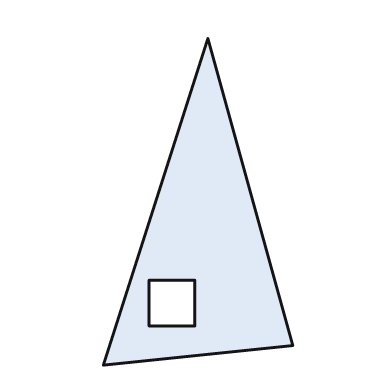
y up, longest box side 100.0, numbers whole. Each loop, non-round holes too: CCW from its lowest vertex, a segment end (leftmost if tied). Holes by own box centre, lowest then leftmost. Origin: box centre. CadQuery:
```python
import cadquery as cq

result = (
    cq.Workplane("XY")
    .moveTo(-29.0, -50.0)
    .lineTo(29.0, -44.0)
    .lineTo(3.0, 50.0)
    .close()
    .moveTo(-15.0, -38.0)
    .lineTo(-1.0, -38.0)
    .lineTo(-1.0, -24.0)
    .lineTo(-15.0, -24.0)
    .close()
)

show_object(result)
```